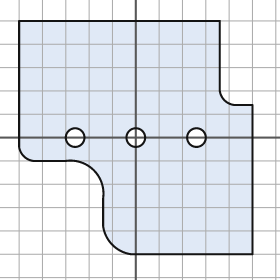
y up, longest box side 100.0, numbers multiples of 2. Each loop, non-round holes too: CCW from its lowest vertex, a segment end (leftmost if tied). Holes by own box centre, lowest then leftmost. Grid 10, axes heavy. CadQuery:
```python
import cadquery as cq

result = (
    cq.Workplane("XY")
    .moveTo(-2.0, -50.0)
    .lineTo(50.0, -50.0)
    .lineTo(50.0, 14.0)
    .lineTo(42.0, 14.0)
    .threePointArc((38.0, 16.0), (36.0, 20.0))
    .lineTo(36.0, 50.0)
    .lineTo(-50.0, 50.0)
    .lineTo(-50.0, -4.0)
    .threePointArc((-48.0, -8.0), (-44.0, -10.0))
    .lineTo(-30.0, -10.0)
    .threePointArc((-18.0, -14.0), (-14.0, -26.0))
    .lineTo(-14.0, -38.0)
    .threePointArc((-10.0, -46.0), (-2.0, -50.0))
    .close()
    .moveTo(-26.0, 0.0)
    .circle(4.0)
    .moveTo(0.0, 0.0)
    .circle(4.0)
    .moveTo(26.0, 0.0)
    .circle(4.0)
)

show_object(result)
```